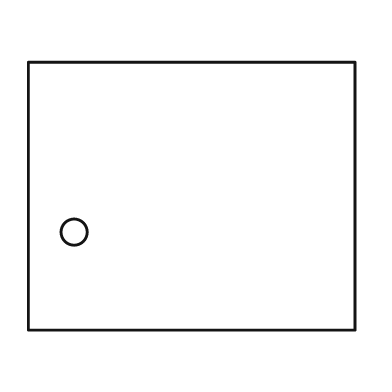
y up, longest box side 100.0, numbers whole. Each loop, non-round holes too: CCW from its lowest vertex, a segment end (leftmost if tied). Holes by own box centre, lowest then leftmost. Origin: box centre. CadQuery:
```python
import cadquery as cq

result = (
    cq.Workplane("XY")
    .moveTo(-50.0, -41.0)
    .lineTo(50.0, -41.0)
    .lineTo(50.0, 41.0)
    .lineTo(-50.0, 41.0)
    .close()
    .moveTo(-36.0, -11.0)
    .circle(4.0)
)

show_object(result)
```